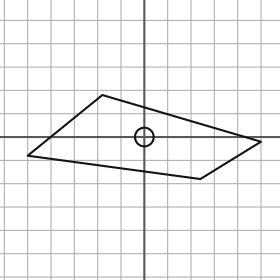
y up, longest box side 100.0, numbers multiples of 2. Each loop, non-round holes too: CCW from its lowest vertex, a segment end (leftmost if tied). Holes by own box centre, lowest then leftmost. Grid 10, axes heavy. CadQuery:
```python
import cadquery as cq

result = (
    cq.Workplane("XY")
    .moveTo(24.0, -18.0)
    .lineTo(50.0, -2.0)
    .lineTo(-18.0, 18.0)
    .lineTo(-50.0, -8.0)
    .close()
    .moveTo(0.0, 0.0)
    .circle(4.0)
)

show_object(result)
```